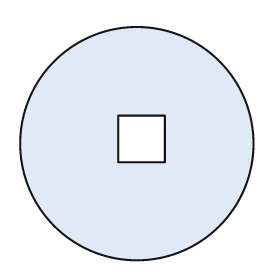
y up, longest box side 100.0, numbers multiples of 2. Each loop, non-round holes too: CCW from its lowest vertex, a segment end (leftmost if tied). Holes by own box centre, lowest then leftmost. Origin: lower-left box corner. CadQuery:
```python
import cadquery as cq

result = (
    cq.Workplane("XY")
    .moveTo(50.0, 50.0)
    .circle(50.0)
    .moveTo(42.0, 42.0)
    .lineTo(62.0, 42.0)
    .lineTo(62.0, 62.0)
    .lineTo(42.0, 62.0)
    .close()
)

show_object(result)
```